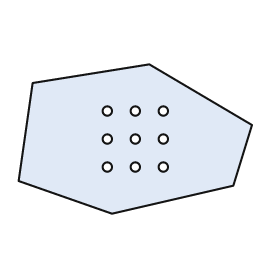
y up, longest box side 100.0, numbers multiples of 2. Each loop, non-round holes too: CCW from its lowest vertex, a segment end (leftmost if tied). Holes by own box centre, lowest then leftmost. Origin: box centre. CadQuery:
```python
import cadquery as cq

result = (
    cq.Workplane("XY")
    .moveTo(-10.0, -32.0)
    .lineTo(42.0, -20.0)
    .lineTo(50.0, 6.0)
    .lineTo(6.0, 32.0)
    .lineTo(-44.0, 24.0)
    .lineTo(-50.0, -18.0)
    .close()
    .moveTo(-12.0, -12.0)
    .circle(2.0)
    .moveTo(0.0, -12.0)
    .circle(2.0)
    .moveTo(12.0, -12.0)
    .circle(2.0)
    .moveTo(-12.0, 0.0)
    .circle(2.0)
    .moveTo(0.0, 0.0)
    .circle(2.0)
    .moveTo(12.0, 0.0)
    .circle(2.0)
    .moveTo(-12.0, 12.0)
    .circle(2.0)
    .moveTo(0.0, 12.0)
    .circle(2.0)
    .moveTo(12.0, 12.0)
    .circle(2.0)
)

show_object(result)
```